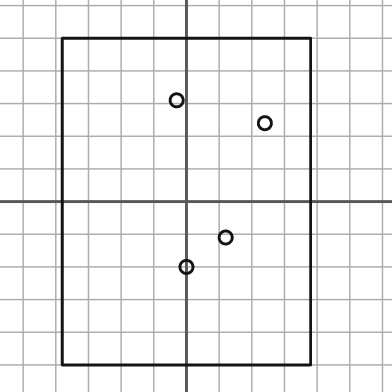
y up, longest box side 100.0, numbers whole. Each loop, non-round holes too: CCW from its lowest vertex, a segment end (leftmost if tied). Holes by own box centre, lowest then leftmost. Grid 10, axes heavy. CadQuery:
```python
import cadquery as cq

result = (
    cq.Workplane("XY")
    .moveTo(-38.0, -50.0)
    .lineTo(38.0, -50.0)
    .lineTo(38.0, 50.0)
    .lineTo(-38.0, 50.0)
    .close()
    .moveTo(0.0, -20.0)
    .circle(2.0)
    .moveTo(12.0, -11.0)
    .circle(2.0)
    .moveTo(24.0, 24.0)
    .circle(2.0)
    .moveTo(-3.0, 31.0)
    .circle(2.0)
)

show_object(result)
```